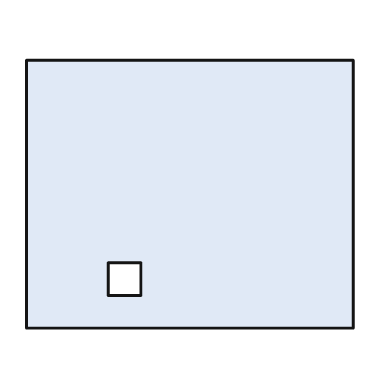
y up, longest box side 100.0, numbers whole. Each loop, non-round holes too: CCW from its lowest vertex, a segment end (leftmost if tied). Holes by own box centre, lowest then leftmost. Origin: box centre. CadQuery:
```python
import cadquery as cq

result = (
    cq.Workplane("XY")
    .moveTo(-50.0, -41.0)
    .lineTo(50.0, -41.0)
    .lineTo(50.0, 41.0)
    .lineTo(-50.0, 41.0)
    .close()
    .moveTo(-25.0, -31.0)
    .lineTo(-15.0, -31.0)
    .lineTo(-15.0, -21.0)
    .lineTo(-25.0, -21.0)
    .close()
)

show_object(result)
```